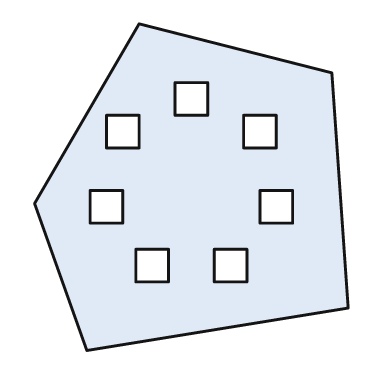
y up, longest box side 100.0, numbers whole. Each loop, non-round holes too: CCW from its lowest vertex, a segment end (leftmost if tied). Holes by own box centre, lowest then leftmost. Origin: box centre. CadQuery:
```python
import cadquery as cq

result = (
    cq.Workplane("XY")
    .moveTo(-32.0, -50.0)
    .lineTo(48.0, -37.0)
    .lineTo(43.0, 35.0)
    .lineTo(-16.0, 50.0)
    .lineTo(-48.0, -5.0)
    .close()
    .moveTo(-17.0, -29.0)
    .lineTo(-7.0, -29.0)
    .lineTo(-7.0, -19.0)
    .lineTo(-17.0, -19.0)
    .close()
    .moveTo(7.0, -29.0)
    .lineTo(17.0, -29.0)
    .lineTo(17.0, -19.0)
    .lineTo(7.0, -19.0)
    .close()
    .moveTo(-31.0, -11.0)
    .lineTo(-21.0, -11.0)
    .lineTo(-21.0, -1.0)
    .lineTo(-31.0, -1.0)
    .close()
    .moveTo(21.0, -11.0)
    .lineTo(31.0, -11.0)
    .lineTo(31.0, -1.0)
    .lineTo(21.0, -1.0)
    .close()
    .moveTo(-26.0, 12.0)
    .lineTo(-16.0, 12.0)
    .lineTo(-16.0, 22.0)
    .lineTo(-26.0, 22.0)
    .close()
    .moveTo(16.0, 12.0)
    .lineTo(26.0, 12.0)
    .lineTo(26.0, 22.0)
    .lineTo(16.0, 22.0)
    .close()
    .moveTo(-5.0, 22.0)
    .lineTo(5.0, 22.0)
    .lineTo(5.0, 32.0)
    .lineTo(-5.0, 32.0)
    .close()
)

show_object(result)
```